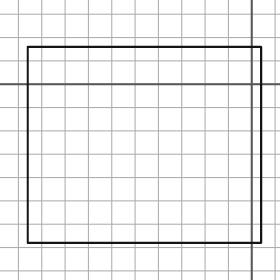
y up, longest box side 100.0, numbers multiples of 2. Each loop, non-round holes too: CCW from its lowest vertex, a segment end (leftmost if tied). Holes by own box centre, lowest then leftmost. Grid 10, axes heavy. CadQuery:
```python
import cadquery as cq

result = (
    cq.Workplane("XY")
    .moveTo(-96.0, -68.0)
    .lineTo(4.0, -68.0)
    .lineTo(4.0, 16.0)
    .lineTo(-96.0, 16.0)
    .close()
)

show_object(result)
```